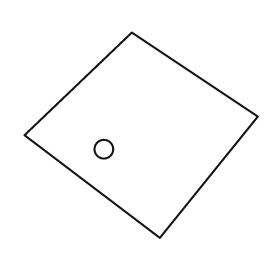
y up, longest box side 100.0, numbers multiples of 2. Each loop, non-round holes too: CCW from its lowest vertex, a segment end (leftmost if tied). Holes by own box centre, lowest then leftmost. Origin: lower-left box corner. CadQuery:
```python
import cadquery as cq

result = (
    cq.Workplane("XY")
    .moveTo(58.0, 0.0)
    .lineTo(100.0, 52.0)
    .lineTo(46.0, 88.0)
    .lineTo(0.0, 44.0)
    .close()
    .moveTo(34.0, 38.0)
    .circle(4.0)
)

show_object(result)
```